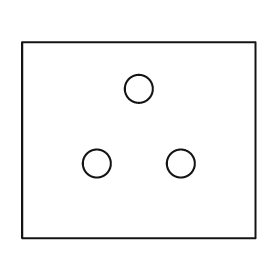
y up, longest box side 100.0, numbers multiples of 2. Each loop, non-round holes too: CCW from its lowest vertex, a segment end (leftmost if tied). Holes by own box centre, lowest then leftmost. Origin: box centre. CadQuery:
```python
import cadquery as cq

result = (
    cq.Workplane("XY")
    .moveTo(-50.0, -42.0)
    .lineTo(50.0, -42.0)
    .lineTo(50.0, 42.0)
    .lineTo(-50.0, 42.0)
    .close()
    .moveTo(-18.0, -10.0)
    .circle(6.0)
    .moveTo(18.0, -10.0)
    .circle(6.0)
    .moveTo(0.0, 22.0)
    .circle(6.0)
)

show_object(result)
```